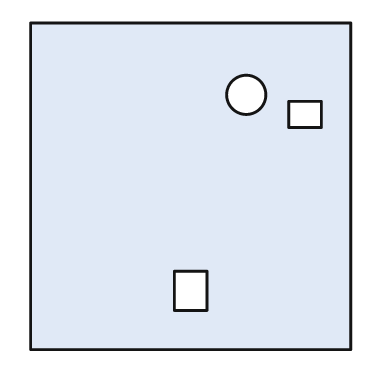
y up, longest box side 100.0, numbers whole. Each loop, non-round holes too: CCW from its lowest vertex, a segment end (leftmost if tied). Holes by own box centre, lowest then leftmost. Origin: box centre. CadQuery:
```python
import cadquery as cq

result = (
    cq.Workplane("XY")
    .moveTo(-49.0, -50.0)
    .lineTo(49.0, -50.0)
    .lineTo(49.0, 50.0)
    .lineTo(-49.0, 50.0)
    .close()
    .moveTo(-5.0, -38.0)
    .lineTo(5.0, -38.0)
    .lineTo(5.0, -26.0)
    .lineTo(-5.0, -26.0)
    .close()
    .moveTo(30.0, 18.0)
    .lineTo(40.0, 18.0)
    .lineTo(40.0, 26.0)
    .lineTo(30.0, 26.0)
    .close()
    .moveTo(17.0, 28.0)
    .circle(6.0)
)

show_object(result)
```